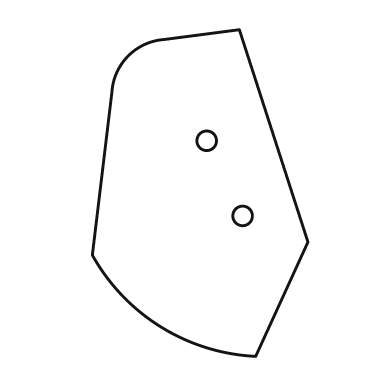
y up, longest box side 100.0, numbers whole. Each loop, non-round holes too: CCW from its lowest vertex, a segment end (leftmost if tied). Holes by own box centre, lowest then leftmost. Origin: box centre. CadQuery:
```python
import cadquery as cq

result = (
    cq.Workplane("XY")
    .moveTo(17.0, -50.0)
    .lineTo(33.0, -15.0)
    .lineTo(12.0, 50.0)
    .lineTo(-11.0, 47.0)
    .threePointArc((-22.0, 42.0), (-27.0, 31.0))
    .lineTo(-33.0, -19.0)
    .threePointArc((-12.0, -41.0), (17.0, -50.0))
    .close()
    .moveTo(13.0, -7.0)
    .circle(3.0)
    .moveTo(2.0, 16.0)
    .circle(3.0)
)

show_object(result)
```